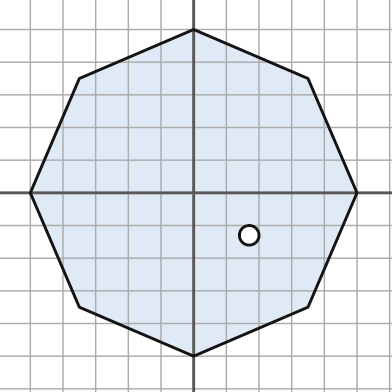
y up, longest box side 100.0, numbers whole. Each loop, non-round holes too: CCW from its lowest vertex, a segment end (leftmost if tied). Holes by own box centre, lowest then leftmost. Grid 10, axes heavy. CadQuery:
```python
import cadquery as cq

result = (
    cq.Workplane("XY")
    .moveTo(0.0, -50.0)
    .lineTo(35.0, -35.0)
    .lineTo(50.0, 0.0)
    .lineTo(35.0, 35.0)
    .lineTo(0.0, 50.0)
    .lineTo(-35.0, 35.0)
    .lineTo(-50.0, 0.0)
    .lineTo(-35.0, -35.0)
    .close()
    .moveTo(17.0, -13.0)
    .circle(3.0)
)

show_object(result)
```